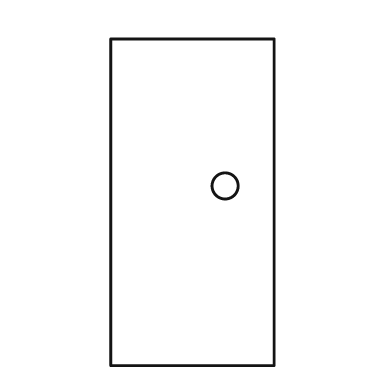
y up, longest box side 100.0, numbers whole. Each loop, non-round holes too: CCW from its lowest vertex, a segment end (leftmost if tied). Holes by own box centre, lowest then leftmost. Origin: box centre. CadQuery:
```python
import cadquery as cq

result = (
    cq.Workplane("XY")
    .moveTo(-25.0, -50.0)
    .lineTo(25.0, -50.0)
    .lineTo(25.0, 50.0)
    .lineTo(-25.0, 50.0)
    .close()
    .moveTo(10.0, 5.0)
    .circle(4.0)
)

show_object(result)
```